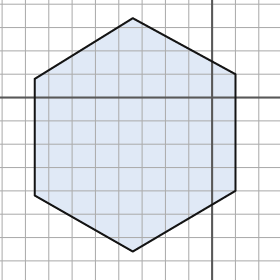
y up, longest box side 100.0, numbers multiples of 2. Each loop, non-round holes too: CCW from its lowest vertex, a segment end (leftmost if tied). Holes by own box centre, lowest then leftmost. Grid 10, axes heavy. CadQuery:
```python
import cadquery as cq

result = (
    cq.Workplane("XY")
    .moveTo(-34.0, -66.0)
    .lineTo(10.0, -40.0)
    .lineTo(10.0, 10.0)
    .lineTo(-34.0, 34.0)
    .lineTo(-76.0, 8.0)
    .lineTo(-76.0, -42.0)
    .close()
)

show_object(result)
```